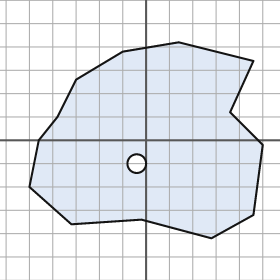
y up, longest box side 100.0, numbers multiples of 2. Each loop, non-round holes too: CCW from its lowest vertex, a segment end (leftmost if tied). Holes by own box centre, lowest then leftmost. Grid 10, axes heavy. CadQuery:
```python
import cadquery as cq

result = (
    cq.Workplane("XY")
    .moveTo(28.0, -42.0)
    .lineTo(46.0, -32.0)
    .lineTo(50.0, -2.0)
    .lineTo(36.0, 12.0)
    .lineTo(46.0, 34.0)
    .lineTo(14.0, 42.0)
    .lineTo(-10.0, 38.0)
    .lineTo(-30.0, 26.0)
    .lineTo(-38.0, 10.0)
    .lineTo(-46.0, 0.0)
    .lineTo(-50.0, -20.0)
    .lineTo(-32.0, -36.0)
    .lineTo(-2.0, -34.0)
    .close()
    .moveTo(-4.0, -10.0)
    .circle(4.0)
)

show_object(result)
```